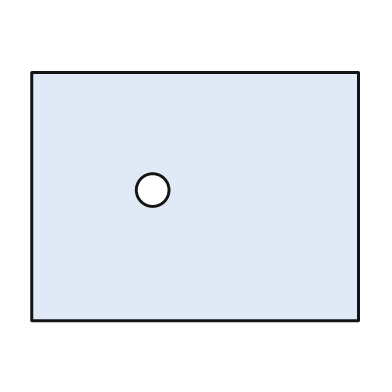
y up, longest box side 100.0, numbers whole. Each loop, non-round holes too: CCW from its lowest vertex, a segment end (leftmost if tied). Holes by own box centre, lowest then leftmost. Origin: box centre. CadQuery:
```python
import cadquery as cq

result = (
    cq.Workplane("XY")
    .moveTo(-50.0, -38.0)
    .lineTo(50.0, -38.0)
    .lineTo(50.0, 38.0)
    .lineTo(-50.0, 38.0)
    .close()
    .moveTo(-13.0, 2.0)
    .circle(5.0)
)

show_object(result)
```